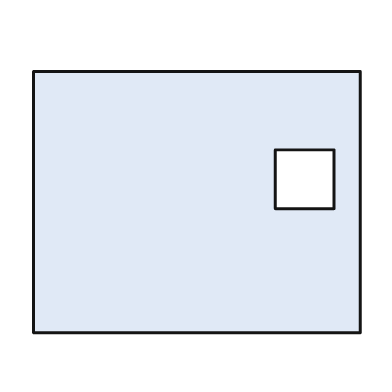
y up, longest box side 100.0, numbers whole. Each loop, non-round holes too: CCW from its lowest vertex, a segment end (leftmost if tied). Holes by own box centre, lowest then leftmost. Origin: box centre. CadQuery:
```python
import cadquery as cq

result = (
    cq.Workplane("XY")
    .moveTo(-50.0, -40.0)
    .lineTo(50.0, -40.0)
    .lineTo(50.0, 40.0)
    .lineTo(-50.0, 40.0)
    .close()
    .moveTo(24.0, -2.0)
    .lineTo(42.0, -2.0)
    .lineTo(42.0, 16.0)
    .lineTo(24.0, 16.0)
    .close()
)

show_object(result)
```